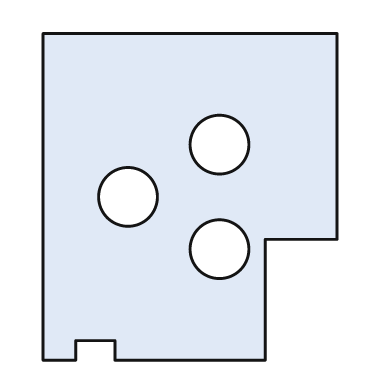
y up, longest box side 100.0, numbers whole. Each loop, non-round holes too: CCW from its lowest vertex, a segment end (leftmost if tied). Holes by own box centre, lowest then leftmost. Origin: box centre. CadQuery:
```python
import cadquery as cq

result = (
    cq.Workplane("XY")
    .moveTo(-45.0, -50.0)
    .lineTo(-35.0, -50.0)
    .lineTo(-35.0, -44.0)
    .lineTo(-23.0, -44.0)
    .lineTo(-23.0, -50.0)
    .lineTo(23.0, -50.0)
    .lineTo(23.0, -13.0)
    .lineTo(45.0, -13.0)
    .lineTo(45.0, 50.0)
    .lineTo(-45.0, 50.0)
    .close()
    .moveTo(9.0, -16.0)
    .circle(9.0)
    .moveTo(-19.0, 0.0)
    .circle(9.0)
    .moveTo(9.0, 16.0)
    .circle(9.0)
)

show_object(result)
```